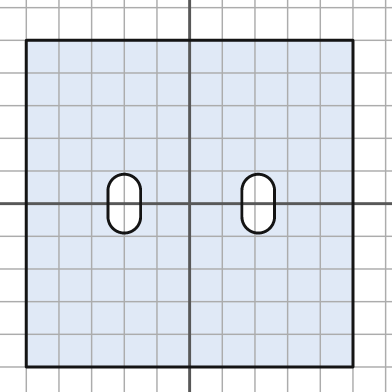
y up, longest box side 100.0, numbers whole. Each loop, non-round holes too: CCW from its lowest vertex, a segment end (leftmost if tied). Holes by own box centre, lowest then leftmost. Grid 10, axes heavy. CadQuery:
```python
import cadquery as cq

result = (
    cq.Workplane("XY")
    .moveTo(-50.0, -50.0)
    .lineTo(50.0, -50.0)
    .lineTo(50.0, 50.0)
    .lineTo(-50.0, 50.0)
    .close()
    .moveTo(-25.0, -4.0)
    .threePointArc((-20.0, -9.0), (-15.0, -4.0))
    .lineTo(-15.0, 4.0)
    .threePointArc((-20.0, 9.0), (-25.0, 4.0))
    .close()
    .moveTo(16.0, -4.0)
    .threePointArc((21.0, -9.0), (26.0, -4.0))
    .lineTo(26.0, 4.0)
    .threePointArc((21.0, 9.0), (16.0, 4.0))
    .close()
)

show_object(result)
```